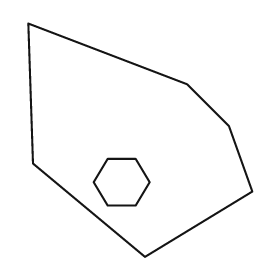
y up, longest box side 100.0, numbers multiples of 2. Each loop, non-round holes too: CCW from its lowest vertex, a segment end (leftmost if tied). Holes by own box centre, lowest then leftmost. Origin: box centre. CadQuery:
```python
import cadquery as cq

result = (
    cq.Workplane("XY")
    .moveTo(2.0, -50.0)
    .lineTo(48.0, -22.0)
    .lineTo(38.0, 6.0)
    .lineTo(20.0, 24.0)
    .lineTo(-48.0, 50.0)
    .lineTo(-46.0, -10.0)
    .close()
    .moveTo(-14.0, -28.0)
    .lineTo(-2.0, -28.0)
    .lineTo(4.0, -18.0)
    .lineTo(-2.0, -8.0)
    .lineTo(-14.0, -8.0)
    .lineTo(-20.0, -18.0)
    .close()
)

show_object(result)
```